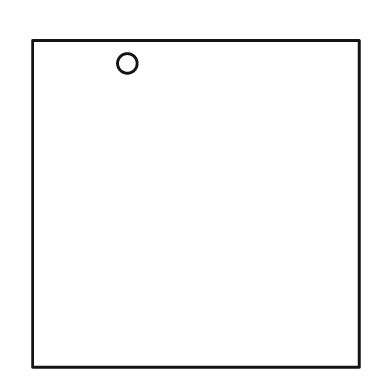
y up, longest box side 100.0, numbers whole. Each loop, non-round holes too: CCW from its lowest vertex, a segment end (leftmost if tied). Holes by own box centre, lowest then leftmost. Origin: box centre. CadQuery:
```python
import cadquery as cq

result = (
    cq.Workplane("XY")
    .moveTo(-50.0, -50.0)
    .lineTo(50.0, -50.0)
    .lineTo(50.0, 50.0)
    .lineTo(-50.0, 50.0)
    .close()
    .moveTo(-21.0, 43.0)
    .circle(3.0)
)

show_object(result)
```